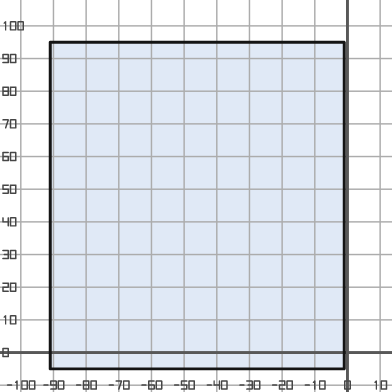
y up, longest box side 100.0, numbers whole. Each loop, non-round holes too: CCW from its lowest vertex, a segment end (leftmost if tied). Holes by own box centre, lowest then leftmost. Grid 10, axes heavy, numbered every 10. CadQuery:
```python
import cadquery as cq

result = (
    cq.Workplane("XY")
    .moveTo(-91.0, -5.0)
    .lineTo(-1.0, -5.0)
    .lineTo(-1.0, 95.0)
    .lineTo(-91.0, 95.0)
    .close()
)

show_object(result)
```